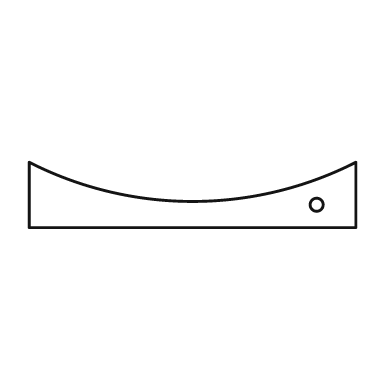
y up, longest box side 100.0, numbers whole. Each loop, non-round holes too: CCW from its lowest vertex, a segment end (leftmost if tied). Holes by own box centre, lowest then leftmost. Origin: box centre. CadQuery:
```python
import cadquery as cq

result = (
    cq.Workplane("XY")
    .moveTo(-50.0, -10.0)
    .lineTo(50.0, -10.0)
    .lineTo(50.0, 10.0)
    .threePointArc((0.0, -2.0), (-50.0, 10.0))
    .close()
    .moveTo(38.0, -3.0)
    .circle(2.0)
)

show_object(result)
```